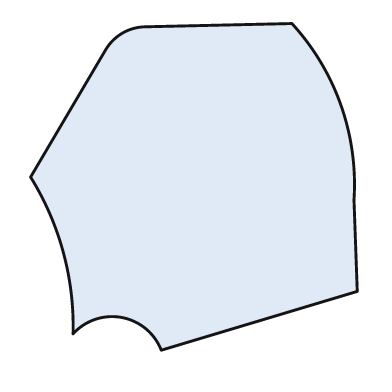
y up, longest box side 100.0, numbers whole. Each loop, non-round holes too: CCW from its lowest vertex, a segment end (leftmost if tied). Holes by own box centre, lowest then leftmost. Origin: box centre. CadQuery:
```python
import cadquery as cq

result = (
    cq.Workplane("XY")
    .moveTo(-10.0, -50.0)
    .lineTo(50.0, -32.0)
    .lineTo(49.0, -4.0)
    .threePointArc((45.0, 25.0), (30.0, 50.0))
    .lineTo(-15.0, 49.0)
    .threePointArc((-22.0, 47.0), (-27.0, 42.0))
    .lineTo(-50.0, 3.0)
    .threePointArc((-40.0, -20.0), (-37.0, -45.0))
    .threePointArc((-22.0, -40.0), (-10.0, -50.0))
    .close()
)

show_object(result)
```